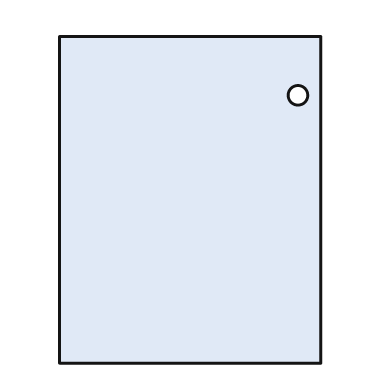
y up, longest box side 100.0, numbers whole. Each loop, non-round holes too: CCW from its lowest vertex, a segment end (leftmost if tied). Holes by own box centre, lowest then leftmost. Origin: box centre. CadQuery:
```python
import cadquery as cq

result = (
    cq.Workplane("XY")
    .moveTo(-40.0, -50.0)
    .lineTo(40.0, -50.0)
    .lineTo(40.0, 50.0)
    .lineTo(-40.0, 50.0)
    .close()
    .moveTo(33.0, 32.0)
    .circle(3.0)
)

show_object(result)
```